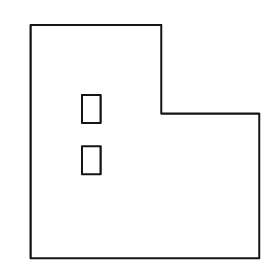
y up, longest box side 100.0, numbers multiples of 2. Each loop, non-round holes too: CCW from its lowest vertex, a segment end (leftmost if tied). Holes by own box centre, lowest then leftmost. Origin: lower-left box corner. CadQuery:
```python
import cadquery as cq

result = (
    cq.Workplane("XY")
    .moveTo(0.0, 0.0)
    .lineTo(98.0, 0.0)
    .lineTo(98.0, 62.0)
    .lineTo(56.0, 62.0)
    .lineTo(56.0, 100.0)
    .lineTo(0.0, 100.0)
    .close()
    .moveTo(22.0, 36.0)
    .lineTo(30.0, 36.0)
    .lineTo(30.0, 48.0)
    .lineTo(22.0, 48.0)
    .close()
    .moveTo(22.0, 58.0)
    .lineTo(30.0, 58.0)
    .lineTo(30.0, 70.0)
    .lineTo(22.0, 70.0)
    .close()
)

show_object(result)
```